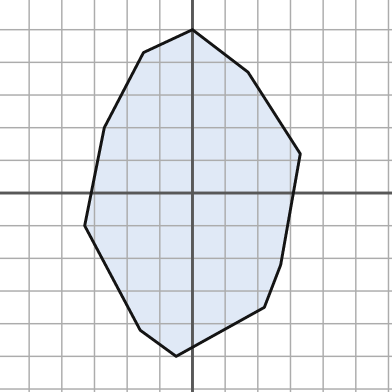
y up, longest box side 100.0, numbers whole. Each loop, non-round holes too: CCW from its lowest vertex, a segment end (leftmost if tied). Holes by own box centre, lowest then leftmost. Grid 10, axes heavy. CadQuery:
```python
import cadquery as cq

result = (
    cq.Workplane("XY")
    .moveTo(-5.0, -50.0)
    .lineTo(22.0, -35.0)
    .lineTo(27.0, -22.0)
    .lineTo(33.0, 12.0)
    .lineTo(17.0, 37.0)
    .lineTo(0.0, 50.0)
    .lineTo(-15.0, 43.0)
    .lineTo(-27.0, 20.0)
    .lineTo(-33.0, -10.0)
    .lineTo(-16.0, -42.0)
    .close()
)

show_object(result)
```